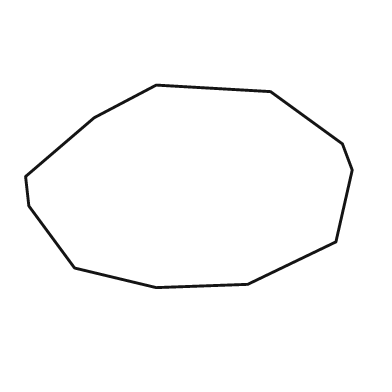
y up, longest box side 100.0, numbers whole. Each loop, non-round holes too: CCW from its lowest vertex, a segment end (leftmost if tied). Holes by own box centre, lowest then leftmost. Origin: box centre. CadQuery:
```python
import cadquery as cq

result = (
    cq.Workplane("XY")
    .moveTo(-10.0, -31.0)
    .lineTo(18.0, -30.0)
    .lineTo(45.0, -17.0)
    .lineTo(50.0, 5.0)
    .lineTo(47.0, 13.0)
    .lineTo(25.0, 29.0)
    .lineTo(-10.0, 31.0)
    .lineTo(-29.0, 21.0)
    .lineTo(-50.0, 3.0)
    .lineTo(-49.0, -6.0)
    .lineTo(-35.0, -25.0)
    .close()
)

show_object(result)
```